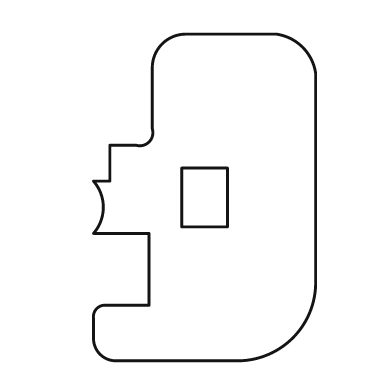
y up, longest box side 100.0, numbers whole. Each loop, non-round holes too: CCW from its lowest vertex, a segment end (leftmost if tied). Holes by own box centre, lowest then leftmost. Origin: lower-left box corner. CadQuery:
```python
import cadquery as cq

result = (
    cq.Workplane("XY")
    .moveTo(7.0, 0.0)
    .lineTo(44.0, 0.0)
    .threePointArc((61.0, 7.0), (68.0, 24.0))
    .lineTo(68.0, 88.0)
    .threePointArc((64.0, 96.0), (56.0, 100.0))
    .lineTo(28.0, 100.0)
    .threePointArc((21.0, 97.0), (18.0, 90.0))
    .lineTo(18.0, 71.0)
    .threePointArc((17.0, 67.0), (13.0, 66.0))
    .lineTo(5.0, 66.0)
    .lineTo(5.0, 55.0)
    .lineTo(0.0, 55.0)
    .threePointArc((3.0, 47.0), (0.0, 39.0))
    .lineTo(17.0, 39.0)
    .lineTo(17.0, 17.0)
    .lineTo(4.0, 17.0)
    .threePointArc((1.0, 16.0), (0.0, 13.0))
    .lineTo(0.0, 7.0)
    .threePointArc((2.0, 2.0), (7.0, 0.0))
    .close()
    .moveTo(27.0, 41.0)
    .lineTo(41.0, 41.0)
    .lineTo(41.0, 59.0)
    .lineTo(27.0, 59.0)
    .close()
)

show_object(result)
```